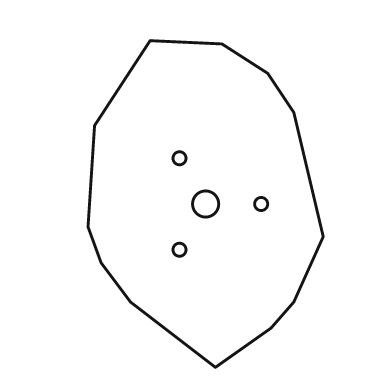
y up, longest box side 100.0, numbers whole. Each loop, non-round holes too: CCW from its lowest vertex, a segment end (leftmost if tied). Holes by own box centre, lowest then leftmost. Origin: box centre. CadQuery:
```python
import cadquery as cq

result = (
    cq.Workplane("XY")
    .moveTo(3.0, -50.0)
    .lineTo(20.0, -38.0)
    .lineTo(27.0, -30.0)
    .lineTo(36.0, -10.0)
    .lineTo(27.0, 28.0)
    .lineTo(19.0, 40.0)
    .lineTo(5.0, 49.0)
    .lineTo(-17.0, 50.0)
    .lineTo(-34.0, 24.0)
    .lineTo(-36.0, -7.0)
    .lineTo(-32.0, -18.0)
    .lineTo(-23.0, -30.0)
    .close()
    .moveTo(-8.0, -14.0)
    .circle(2.0)
    .moveTo(0.0, 0.0)
    .circle(4.0)
    .moveTo(17.0, 0.0)
    .circle(2.0)
    .moveTo(-8.0, 14.0)
    .circle(2.0)
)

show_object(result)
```